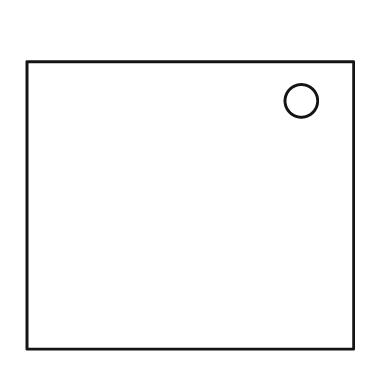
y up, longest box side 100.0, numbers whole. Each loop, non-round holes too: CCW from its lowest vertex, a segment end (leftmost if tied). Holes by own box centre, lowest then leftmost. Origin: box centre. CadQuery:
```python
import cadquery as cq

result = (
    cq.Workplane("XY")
    .moveTo(-50.0, -44.0)
    .lineTo(50.0, -44.0)
    .lineTo(50.0, 44.0)
    .lineTo(-50.0, 44.0)
    .close()
    .moveTo(34.0, 32.0)
    .circle(5.0)
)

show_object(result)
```